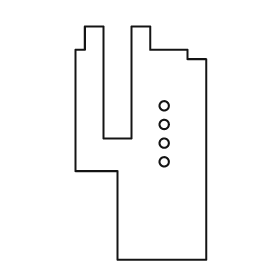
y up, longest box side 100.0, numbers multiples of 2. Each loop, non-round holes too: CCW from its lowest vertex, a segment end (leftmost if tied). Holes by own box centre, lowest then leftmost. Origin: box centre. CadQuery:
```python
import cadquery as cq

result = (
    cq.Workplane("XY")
    .moveTo(-10.0, -50.0)
    .lineTo(28.0, -50.0)
    .lineTo(28.0, 36.0)
    .lineTo(20.0, 36.0)
    .lineTo(20.0, 40.0)
    .lineTo(4.0, 40.0)
    .lineTo(4.0, 50.0)
    .lineTo(-4.0, 50.0)
    .lineTo(-4.0, 2.0)
    .lineTo(-16.0, 2.0)
    .lineTo(-16.0, 50.0)
    .lineTo(-24.0, 50.0)
    .lineTo(-24.0, 40.0)
    .lineTo(-28.0, 40.0)
    .lineTo(-28.0, -12.0)
    .lineTo(-10.0, -12.0)
    .close()
    .moveTo(10.0, -8.0)
    .circle(2.0)
    .moveTo(10.0, 0.0)
    .circle(2.0)
    .moveTo(10.0, 8.0)
    .circle(2.0)
    .moveTo(10.0, 16.0)
    .circle(2.0)
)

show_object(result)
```